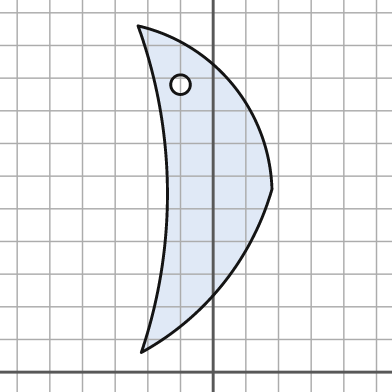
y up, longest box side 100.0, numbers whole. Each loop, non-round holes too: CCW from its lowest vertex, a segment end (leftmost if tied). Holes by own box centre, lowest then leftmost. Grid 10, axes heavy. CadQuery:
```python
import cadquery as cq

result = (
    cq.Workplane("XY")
    .moveTo(-22.0, 6.0)
    .threePointArc((3.0, 27.0), (18.0, 56.0))
    .threePointArc((6.0, 88.0), (-23.0, 106.0))
    .threePointArc((-14.0, 56.0), (-22.0, 6.0))
    .close()
    .moveTo(-10.0, 88.0)
    .circle(3.0)
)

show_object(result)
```